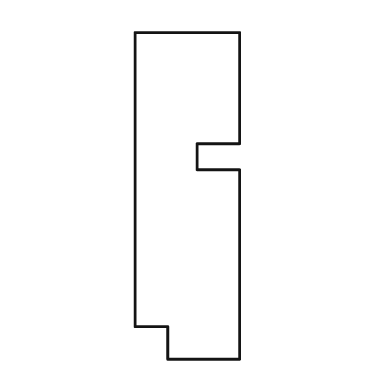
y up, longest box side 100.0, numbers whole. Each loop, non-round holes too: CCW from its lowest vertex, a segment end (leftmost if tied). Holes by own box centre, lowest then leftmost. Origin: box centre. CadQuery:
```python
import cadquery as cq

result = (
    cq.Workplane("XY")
    .moveTo(-6.0, -50.0)
    .lineTo(16.0, -50.0)
    .lineTo(16.0, 8.0)
    .lineTo(3.0, 8.0)
    .lineTo(3.0, 16.0)
    .lineTo(16.0, 16.0)
    .lineTo(16.0, 50.0)
    .lineTo(-16.0, 50.0)
    .lineTo(-16.0, -40.0)
    .lineTo(-6.0, -40.0)
    .close()
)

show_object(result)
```